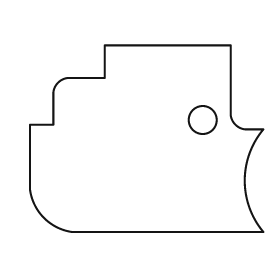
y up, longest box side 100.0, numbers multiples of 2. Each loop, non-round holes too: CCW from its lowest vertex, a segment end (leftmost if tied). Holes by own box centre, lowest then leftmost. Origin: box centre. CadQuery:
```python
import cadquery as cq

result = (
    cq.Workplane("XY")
    .moveTo(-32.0, -40.0)
    .lineTo(50.0, -40.0)
    .threePointArc((42.0, -18.0), (50.0, 4.0))
    .lineTo(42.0, 4.0)
    .threePointArc((38.0, 6.0), (36.0, 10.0))
    .lineTo(36.0, 40.0)
    .lineTo(-18.0, 40.0)
    .lineTo(-18.0, 26.0)
    .lineTo(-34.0, 26.0)
    .threePointArc((-38.0, 24.0), (-40.0, 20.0))
    .lineTo(-40.0, 6.0)
    .lineTo(-50.0, 6.0)
    .lineTo(-50.0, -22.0)
    .threePointArc((-44.0, -34.0), (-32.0, -40.0))
    .close()
    .moveTo(24.0, 8.0)
    .circle(6.0)
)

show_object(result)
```